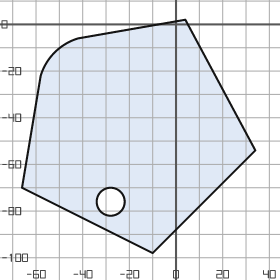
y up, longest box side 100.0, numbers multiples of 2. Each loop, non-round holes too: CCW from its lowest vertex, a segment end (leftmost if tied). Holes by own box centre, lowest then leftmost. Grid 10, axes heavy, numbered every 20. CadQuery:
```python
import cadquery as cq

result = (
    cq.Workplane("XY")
    .moveTo(-10.0, -98.0)
    .lineTo(34.0, -54.0)
    .lineTo(4.0, 2.0)
    .lineTo(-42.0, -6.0)
    .threePointArc((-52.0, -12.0), (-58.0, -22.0))
    .lineTo(-66.0, -70.0)
    .close()
    .moveTo(-28.0, -76.0)
    .circle(6.0)
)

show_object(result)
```